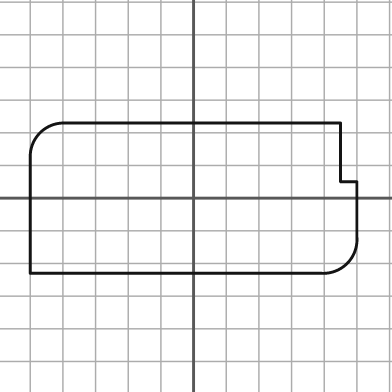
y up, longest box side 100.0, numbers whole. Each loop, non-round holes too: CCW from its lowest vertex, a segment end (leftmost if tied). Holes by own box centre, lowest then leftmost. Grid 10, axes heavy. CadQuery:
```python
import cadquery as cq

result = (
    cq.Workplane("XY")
    .moveTo(-50.0, -23.0)
    .lineTo(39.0, -23.0)
    .threePointArc((47.0, -20.0), (50.0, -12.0))
    .lineTo(50.0, 5.0)
    .lineTo(45.0, 5.0)
    .lineTo(45.0, 23.0)
    .lineTo(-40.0, 23.0)
    .threePointArc((-47.0, 20.0), (-50.0, 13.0))
    .close()
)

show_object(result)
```